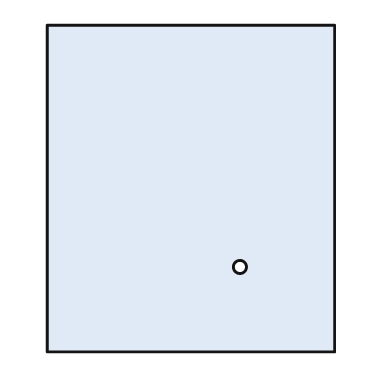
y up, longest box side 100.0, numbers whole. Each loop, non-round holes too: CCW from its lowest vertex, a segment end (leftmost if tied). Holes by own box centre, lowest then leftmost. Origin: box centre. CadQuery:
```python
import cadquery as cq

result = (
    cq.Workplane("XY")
    .moveTo(-44.0, -50.0)
    .lineTo(44.0, -50.0)
    .lineTo(44.0, 50.0)
    .lineTo(-44.0, 50.0)
    .close()
    .moveTo(15.0, -24.0)
    .circle(2.0)
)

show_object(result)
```